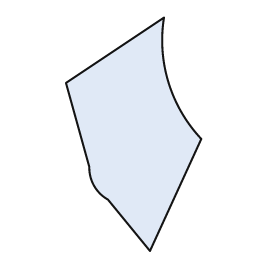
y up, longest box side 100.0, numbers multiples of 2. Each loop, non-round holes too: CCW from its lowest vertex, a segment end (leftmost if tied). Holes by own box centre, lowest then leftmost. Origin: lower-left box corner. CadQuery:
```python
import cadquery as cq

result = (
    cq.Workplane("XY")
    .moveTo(36.0, 0.0)
    .lineTo(58.0, 48.0)
    .threePointArc((44.0, 72.0), (42.0, 100.0))
    .lineTo(0.0, 72.0)
    .lineTo(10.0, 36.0)
    .threePointArc((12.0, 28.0), (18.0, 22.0))
    .close()
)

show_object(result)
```